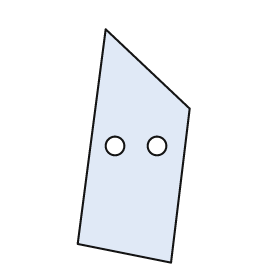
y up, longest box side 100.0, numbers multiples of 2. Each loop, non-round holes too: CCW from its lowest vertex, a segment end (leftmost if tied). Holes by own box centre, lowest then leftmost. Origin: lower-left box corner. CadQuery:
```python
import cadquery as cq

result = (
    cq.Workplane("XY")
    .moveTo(40.0, 0.0)
    .lineTo(48.0, 66.0)
    .lineTo(12.0, 100.0)
    .lineTo(0.0, 8.0)
    .close()
    .moveTo(16.0, 50.0)
    .circle(4.0)
    .moveTo(34.0, 50.0)
    .circle(4.0)
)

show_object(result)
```